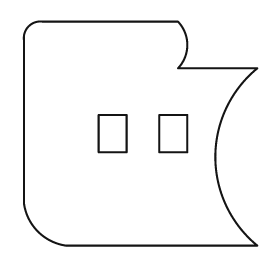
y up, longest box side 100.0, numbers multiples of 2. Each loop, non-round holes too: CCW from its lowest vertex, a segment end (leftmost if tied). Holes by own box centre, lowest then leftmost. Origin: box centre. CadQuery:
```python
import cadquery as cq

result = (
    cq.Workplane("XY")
    .moveTo(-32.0, -48.0)
    .lineTo(50.0, -48.0)
    .threePointArc((32.0, -10.0), (50.0, 28.0))
    .lineTo(16.0, 28.0)
    .threePointArc((20.0, 38.0), (16.0, 48.0))
    .lineTo(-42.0, 48.0)
    .threePointArc((-48.0, 46.0), (-50.0, 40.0))
    .lineTo(-50.0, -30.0)
    .threePointArc((-44.0, -42.0), (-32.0, -48.0))
    .close()
    .moveTo(-18.0, -8.0)
    .lineTo(-6.0, -8.0)
    .lineTo(-6.0, 8.0)
    .lineTo(-18.0, 8.0)
    .close()
    .moveTo(8.0, -8.0)
    .lineTo(20.0, -8.0)
    .lineTo(20.0, 8.0)
    .lineTo(8.0, 8.0)
    .close()
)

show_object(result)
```